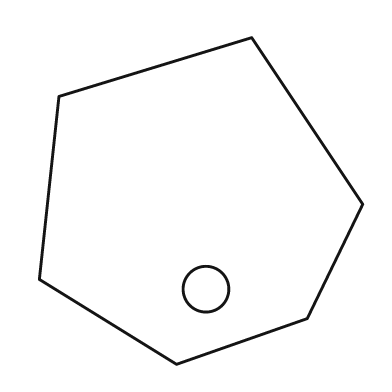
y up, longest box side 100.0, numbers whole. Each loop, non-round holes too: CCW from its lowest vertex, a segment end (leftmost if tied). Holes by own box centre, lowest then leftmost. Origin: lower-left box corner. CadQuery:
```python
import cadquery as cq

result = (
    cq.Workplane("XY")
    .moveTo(42.0, 0.0)
    .lineTo(82.0, 14.0)
    .lineTo(99.0, 49.0)
    .lineTo(65.0, 100.0)
    .lineTo(6.0, 82.0)
    .lineTo(0.0, 26.0)
    .close()
    .moveTo(51.0, 23.0)
    .circle(7.0)
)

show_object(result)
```